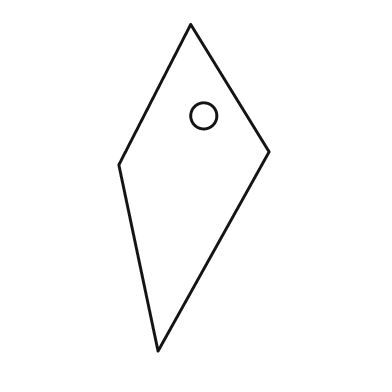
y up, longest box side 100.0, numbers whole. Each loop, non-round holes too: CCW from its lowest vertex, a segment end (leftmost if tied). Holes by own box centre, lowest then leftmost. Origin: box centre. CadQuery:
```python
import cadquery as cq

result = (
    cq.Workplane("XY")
    .moveTo(-11.0, -50.0)
    .lineTo(23.0, 11.0)
    .lineTo(-1.0, 50.0)
    .lineTo(-23.0, 7.0)
    .close()
    .moveTo(3.0, 22.0)
    .circle(4.0)
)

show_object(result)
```